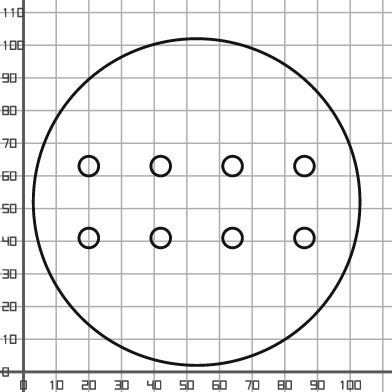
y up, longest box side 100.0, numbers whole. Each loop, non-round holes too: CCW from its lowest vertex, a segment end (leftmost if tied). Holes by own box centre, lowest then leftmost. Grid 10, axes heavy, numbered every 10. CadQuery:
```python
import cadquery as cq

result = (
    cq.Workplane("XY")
    .moveTo(53.0, 52.0)
    .circle(50.0)
    .moveTo(20.0, 41.0)
    .circle(3.0)
    .moveTo(42.0, 41.0)
    .circle(3.0)
    .moveTo(64.0, 41.0)
    .circle(3.0)
    .moveTo(86.0, 41.0)
    .circle(3.0)
    .moveTo(20.0, 63.0)
    .circle(3.0)
    .moveTo(42.0, 63.0)
    .circle(3.0)
    .moveTo(64.0, 63.0)
    .circle(3.0)
    .moveTo(86.0, 63.0)
    .circle(3.0)
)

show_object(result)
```